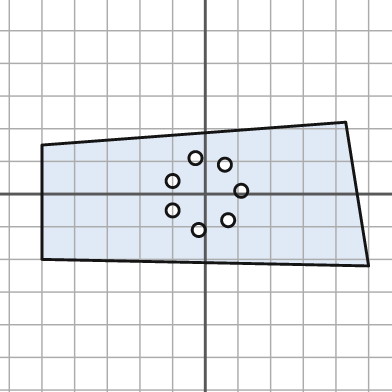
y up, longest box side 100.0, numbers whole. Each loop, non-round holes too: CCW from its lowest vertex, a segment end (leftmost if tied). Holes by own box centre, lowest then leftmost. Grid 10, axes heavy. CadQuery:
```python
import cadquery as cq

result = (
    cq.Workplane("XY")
    .moveTo(50.0, -22.0)
    .lineTo(43.0, 22.0)
    .lineTo(-50.0, 15.0)
    .lineTo(-50.0, -20.0)
    .close()
    .moveTo(-2.0, -11.0)
    .circle(2.0)
    .moveTo(7.0, -8.0)
    .circle(2.0)
    .moveTo(-10.0, -5.0)
    .circle(2.0)
    .moveTo(11.0, 1.0)
    .circle(2.0)
    .moveTo(-10.0, 4.0)
    .circle(2.0)
    .moveTo(6.0, 9.0)
    .circle(2.0)
    .moveTo(-3.0, 11.0)
    .circle(2.0)
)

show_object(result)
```